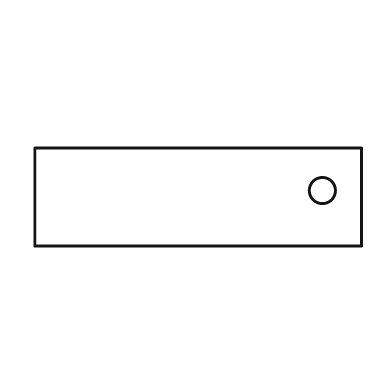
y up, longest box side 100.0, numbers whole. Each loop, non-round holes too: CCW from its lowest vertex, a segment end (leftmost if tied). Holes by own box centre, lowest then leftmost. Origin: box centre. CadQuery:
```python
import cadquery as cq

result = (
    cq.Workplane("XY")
    .moveTo(-50.0, -15.0)
    .lineTo(50.0, -15.0)
    .lineTo(50.0, 15.0)
    .lineTo(-50.0, 15.0)
    .close()
    .moveTo(38.0, 2.0)
    .circle(4.0)
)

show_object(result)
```